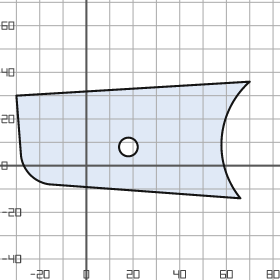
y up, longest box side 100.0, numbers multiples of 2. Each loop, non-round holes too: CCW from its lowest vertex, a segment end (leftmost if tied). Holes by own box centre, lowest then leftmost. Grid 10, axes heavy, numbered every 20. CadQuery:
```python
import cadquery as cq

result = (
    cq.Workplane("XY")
    .moveTo(66.0, -14.0)
    .threePointArc((58.0, 12.0), (70.0, 36.0))
    .lineTo(-30.0, 30.0)
    .lineTo(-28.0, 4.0)
    .threePointArc((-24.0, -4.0), (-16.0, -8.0))
    .close()
    .moveTo(18.0, 8.0)
    .circle(4.0)
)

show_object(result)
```